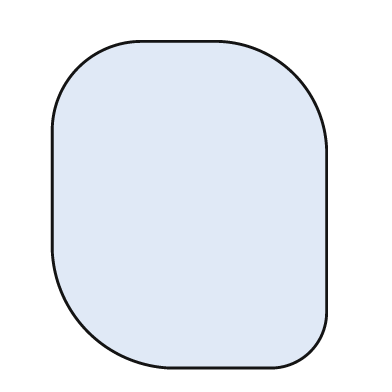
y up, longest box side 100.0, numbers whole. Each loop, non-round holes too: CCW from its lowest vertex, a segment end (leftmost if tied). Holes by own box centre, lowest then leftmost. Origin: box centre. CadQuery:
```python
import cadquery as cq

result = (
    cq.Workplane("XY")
    .moveTo(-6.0, -50.0)
    .lineTo(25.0, -50.0)
    .threePointArc((37.0, -45.0), (42.0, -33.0))
    .lineTo(42.0, 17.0)
    .threePointArc((32.0, 40.0), (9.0, 50.0))
    .lineTo(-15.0, 50.0)
    .threePointArc((-34.0, 42.0), (-42.0, 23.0))
    .lineTo(-42.0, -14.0)
    .threePointArc((-31.0, -39.0), (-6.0, -50.0))
    .close()
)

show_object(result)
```